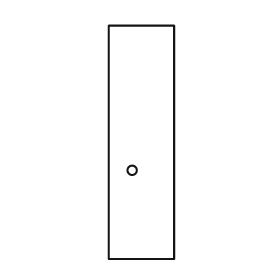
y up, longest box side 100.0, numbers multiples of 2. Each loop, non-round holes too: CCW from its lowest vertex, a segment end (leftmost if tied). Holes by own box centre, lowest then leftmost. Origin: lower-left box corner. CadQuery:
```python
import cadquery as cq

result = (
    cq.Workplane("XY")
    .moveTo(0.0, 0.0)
    .lineTo(28.0, 0.0)
    .lineTo(28.0, 100.0)
    .lineTo(0.0, 100.0)
    .close()
    .moveTo(10.0, 38.0)
    .circle(2.0)
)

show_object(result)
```